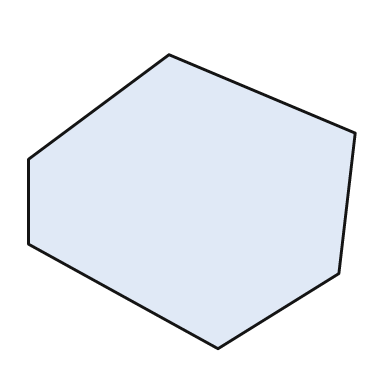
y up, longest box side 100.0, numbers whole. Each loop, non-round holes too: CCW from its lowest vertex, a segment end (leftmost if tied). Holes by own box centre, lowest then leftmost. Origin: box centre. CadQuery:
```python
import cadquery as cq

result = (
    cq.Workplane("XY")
    .moveTo(8.0, -45.0)
    .lineTo(45.0, -22.0)
    .lineTo(50.0, 21.0)
    .lineTo(-7.0, 45.0)
    .lineTo(-50.0, 13.0)
    .lineTo(-50.0, -13.0)
    .close()
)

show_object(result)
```